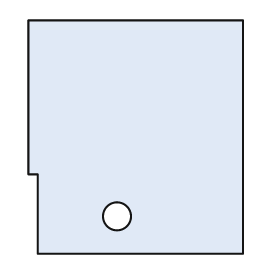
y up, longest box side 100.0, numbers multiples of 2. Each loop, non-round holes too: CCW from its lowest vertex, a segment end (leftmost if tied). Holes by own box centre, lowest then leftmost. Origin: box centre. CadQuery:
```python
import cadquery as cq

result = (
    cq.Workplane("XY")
    .moveTo(-42.0, -50.0)
    .lineTo(46.0, -50.0)
    .lineTo(46.0, 50.0)
    .lineTo(-46.0, 50.0)
    .lineTo(-46.0, -16.0)
    .lineTo(-42.0, -16.0)
    .close()
    .moveTo(-8.0, -34.0)
    .circle(6.0)
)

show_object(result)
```